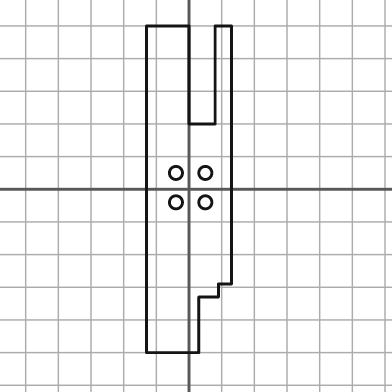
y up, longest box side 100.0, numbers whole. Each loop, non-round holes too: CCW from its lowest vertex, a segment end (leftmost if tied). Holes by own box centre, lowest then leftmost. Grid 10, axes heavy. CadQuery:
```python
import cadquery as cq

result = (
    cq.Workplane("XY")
    .moveTo(-13.0, -50.0)
    .lineTo(3.0, -50.0)
    .lineTo(3.0, -33.0)
    .lineTo(9.0, -33.0)
    .lineTo(9.0, -29.0)
    .lineTo(13.0, -29.0)
    .lineTo(13.0, 50.0)
    .lineTo(8.0, 50.0)
    .lineTo(8.0, 20.0)
    .lineTo(0.0, 20.0)
    .lineTo(0.0, 50.0)
    .lineTo(-13.0, 50.0)
    .close()
    .moveTo(-4.0, -4.0)
    .circle(2.0)
    .moveTo(5.0, -4.0)
    .circle(2.0)
    .moveTo(-4.0, 5.0)
    .circle(2.0)
    .moveTo(5.0, 5.0)
    .circle(2.0)
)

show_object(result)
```